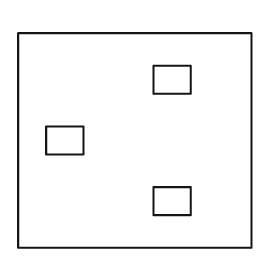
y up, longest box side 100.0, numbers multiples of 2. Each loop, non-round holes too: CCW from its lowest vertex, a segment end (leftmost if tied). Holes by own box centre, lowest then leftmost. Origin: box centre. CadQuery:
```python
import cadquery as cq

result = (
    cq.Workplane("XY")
    .moveTo(-50.0, -46.0)
    .lineTo(50.0, -46.0)
    .lineTo(50.0, 46.0)
    .lineTo(-50.0, 46.0)
    .close()
    .moveTo(8.0, -32.0)
    .lineTo(24.0, -32.0)
    .lineTo(24.0, -20.0)
    .lineTo(8.0, -20.0)
    .close()
    .moveTo(-38.0, -6.0)
    .lineTo(-22.0, -6.0)
    .lineTo(-22.0, 6.0)
    .lineTo(-38.0, 6.0)
    .close()
    .moveTo(8.0, 20.0)
    .lineTo(24.0, 20.0)
    .lineTo(24.0, 32.0)
    .lineTo(8.0, 32.0)
    .close()
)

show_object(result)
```